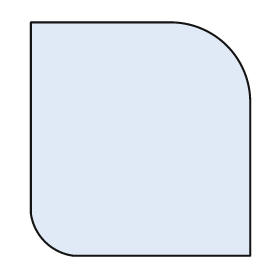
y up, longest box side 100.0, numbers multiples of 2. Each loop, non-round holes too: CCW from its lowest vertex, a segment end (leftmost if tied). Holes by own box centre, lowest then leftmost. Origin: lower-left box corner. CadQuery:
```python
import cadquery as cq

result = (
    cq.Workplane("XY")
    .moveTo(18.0, 0.0)
    .lineTo(94.0, 0.0)
    .lineTo(94.0, 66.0)
    .threePointArc((84.0, 90.0), (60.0, 100.0))
    .lineTo(0.0, 100.0)
    .lineTo(0.0, 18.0)
    .threePointArc((6.0, 6.0), (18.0, 0.0))
    .close()
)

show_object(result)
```